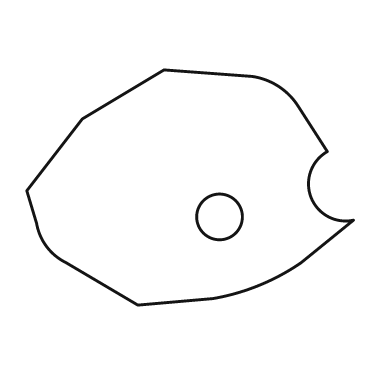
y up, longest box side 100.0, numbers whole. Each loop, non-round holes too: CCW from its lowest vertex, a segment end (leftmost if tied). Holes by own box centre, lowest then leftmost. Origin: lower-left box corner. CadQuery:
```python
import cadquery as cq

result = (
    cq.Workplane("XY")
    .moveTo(34.0, 0.0)
    .lineTo(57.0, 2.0)
    .threePointArc((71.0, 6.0), (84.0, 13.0))
    .lineTo(100.0, 26.0)
    .threePointArc((87.0, 33.0), (92.0, 47.0))
    .lineTo(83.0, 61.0)
    .threePointArc((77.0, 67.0), (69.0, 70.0))
    .lineTo(42.0, 72.0)
    .lineTo(17.0, 57.0)
    .lineTo(0.0, 35.0)
    .lineTo(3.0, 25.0)
    .threePointArc((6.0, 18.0), (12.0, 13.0))
    .close()
    .moveTo(59.0, 27.0)
    .circle(7.0)
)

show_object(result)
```